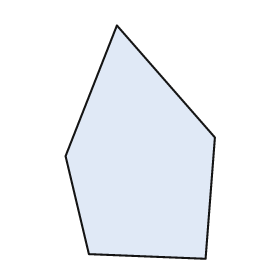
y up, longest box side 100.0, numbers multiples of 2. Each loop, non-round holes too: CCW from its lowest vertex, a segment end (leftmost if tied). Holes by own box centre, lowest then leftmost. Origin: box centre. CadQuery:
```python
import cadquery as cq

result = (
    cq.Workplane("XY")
    .moveTo(28.0, -50.0)
    .lineTo(32.0, 2.0)
    .lineTo(-10.0, 50.0)
    .lineTo(-32.0, -6.0)
    .lineTo(-22.0, -48.0)
    .close()
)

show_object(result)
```